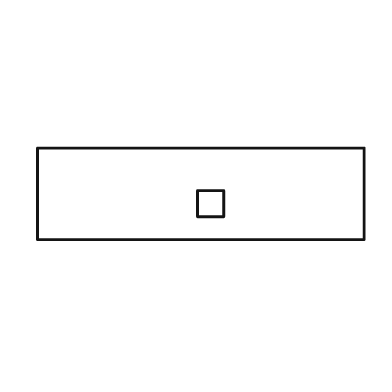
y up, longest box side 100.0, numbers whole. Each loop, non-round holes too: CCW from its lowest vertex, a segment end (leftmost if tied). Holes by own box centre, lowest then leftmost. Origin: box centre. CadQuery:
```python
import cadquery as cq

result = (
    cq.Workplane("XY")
    .moveTo(-50.0, -14.0)
    .lineTo(50.0, -14.0)
    .lineTo(50.0, 14.0)
    .lineTo(-50.0, 14.0)
    .close()
    .moveTo(-1.0, -7.0)
    .lineTo(7.0, -7.0)
    .lineTo(7.0, 1.0)
    .lineTo(-1.0, 1.0)
    .close()
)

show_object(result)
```